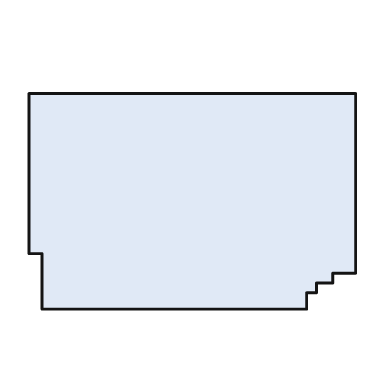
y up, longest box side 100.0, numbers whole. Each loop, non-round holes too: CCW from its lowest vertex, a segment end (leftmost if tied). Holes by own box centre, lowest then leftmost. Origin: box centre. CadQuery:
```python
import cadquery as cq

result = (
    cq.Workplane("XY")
    .moveTo(-46.0, -33.0)
    .lineTo(35.0, -33.0)
    .lineTo(35.0, -28.0)
    .lineTo(38.0, -28.0)
    .lineTo(38.0, -25.0)
    .lineTo(43.0, -25.0)
    .lineTo(43.0, -22.0)
    .lineTo(50.0, -22.0)
    .lineTo(50.0, 33.0)
    .lineTo(-50.0, 33.0)
    .lineTo(-50.0, -16.0)
    .lineTo(-46.0, -16.0)
    .close()
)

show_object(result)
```